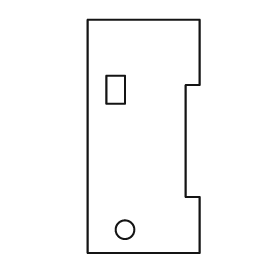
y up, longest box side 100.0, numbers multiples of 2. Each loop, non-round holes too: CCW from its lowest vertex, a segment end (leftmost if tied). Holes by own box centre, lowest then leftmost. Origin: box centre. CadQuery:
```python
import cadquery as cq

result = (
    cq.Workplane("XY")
    .moveTo(-24.0, -50.0)
    .lineTo(24.0, -50.0)
    .lineTo(24.0, -26.0)
    .lineTo(18.0, -26.0)
    .lineTo(18.0, 22.0)
    .lineTo(24.0, 22.0)
    .lineTo(24.0, 50.0)
    .lineTo(-24.0, 50.0)
    .close()
    .moveTo(-8.0, -40.0)
    .circle(4.0)
    .moveTo(-16.0, 14.0)
    .lineTo(-8.0, 14.0)
    .lineTo(-8.0, 26.0)
    .lineTo(-16.0, 26.0)
    .close()
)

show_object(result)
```